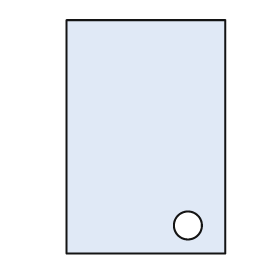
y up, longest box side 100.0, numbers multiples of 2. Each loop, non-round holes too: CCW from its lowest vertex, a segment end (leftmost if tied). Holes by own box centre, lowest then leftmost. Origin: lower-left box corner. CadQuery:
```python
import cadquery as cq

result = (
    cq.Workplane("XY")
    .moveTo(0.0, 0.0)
    .lineTo(68.0, 0.0)
    .lineTo(68.0, 100.0)
    .lineTo(0.0, 100.0)
    .close()
    .moveTo(52.0, 12.0)
    .circle(6.0)
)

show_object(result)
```